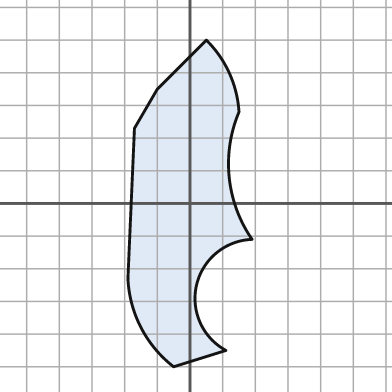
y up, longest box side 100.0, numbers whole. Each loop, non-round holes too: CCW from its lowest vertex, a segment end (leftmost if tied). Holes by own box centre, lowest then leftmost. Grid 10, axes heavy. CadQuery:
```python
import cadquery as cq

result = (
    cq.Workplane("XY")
    .moveTo(-5.0, -50.0)
    .lineTo(11.0, -45.0)
    .threePointArc((2.0, -25.0), (19.0, -11.0))
    .threePointArc((12.0, 8.0), (15.0, 28.0))
    .threePointArc((12.0, 40.0), (5.0, 50.0))
    .lineTo(-10.0, 35.0)
    .lineTo(-17.0, 23.0)
    .lineTo(-19.0, -23.0)
    .threePointArc((-15.0, -38.0), (-5.0, -50.0))
    .close()
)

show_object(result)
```